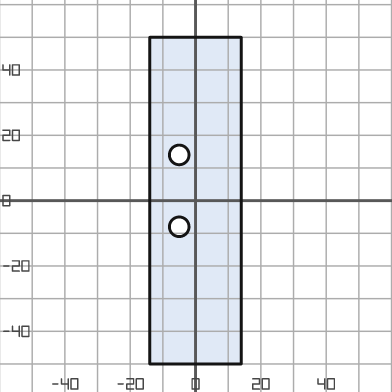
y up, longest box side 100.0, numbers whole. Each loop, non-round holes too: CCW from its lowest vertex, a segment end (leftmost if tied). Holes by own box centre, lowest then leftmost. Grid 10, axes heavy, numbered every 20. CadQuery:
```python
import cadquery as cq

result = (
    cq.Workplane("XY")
    .moveTo(-14.0, -50.0)
    .lineTo(14.0, -50.0)
    .lineTo(14.0, 50.0)
    .lineTo(-14.0, 50.0)
    .close()
    .moveTo(-5.0, -8.0)
    .circle(3.0)
    .moveTo(-5.0, 14.0)
    .circle(3.0)
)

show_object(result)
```